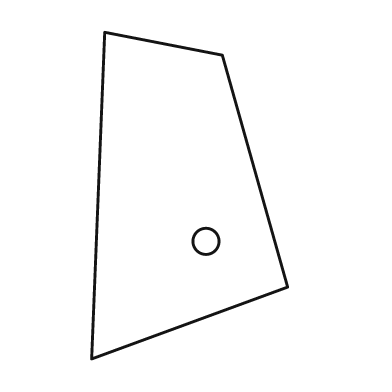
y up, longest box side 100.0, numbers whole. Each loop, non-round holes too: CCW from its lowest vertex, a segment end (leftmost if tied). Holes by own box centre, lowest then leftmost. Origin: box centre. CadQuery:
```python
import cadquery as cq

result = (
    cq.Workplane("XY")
    .moveTo(-30.0, -50.0)
    .lineTo(30.0, -28.0)
    .lineTo(10.0, 43.0)
    .lineTo(-26.0, 50.0)
    .close()
    .moveTo(5.0, -14.0)
    .circle(4.0)
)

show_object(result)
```